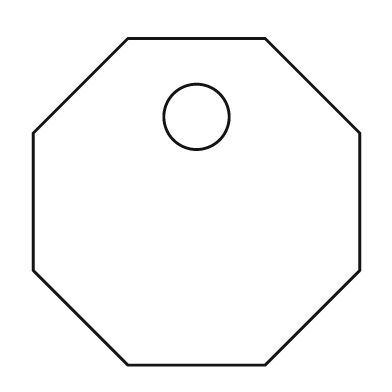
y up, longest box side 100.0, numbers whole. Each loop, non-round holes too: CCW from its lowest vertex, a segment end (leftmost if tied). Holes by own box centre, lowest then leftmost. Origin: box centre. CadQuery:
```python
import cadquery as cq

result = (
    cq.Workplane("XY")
    .moveTo(-21.0, -50.0)
    .lineTo(21.0, -50.0)
    .lineTo(50.0, -21.0)
    .lineTo(50.0, 21.0)
    .lineTo(21.0, 50.0)
    .lineTo(-21.0, 50.0)
    .lineTo(-50.0, 21.0)
    .lineTo(-50.0, -21.0)
    .close()
    .moveTo(0.0, 26.0)
    .circle(10.0)
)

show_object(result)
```